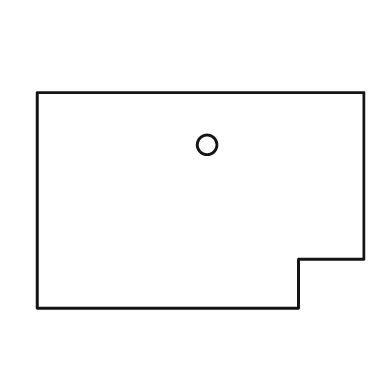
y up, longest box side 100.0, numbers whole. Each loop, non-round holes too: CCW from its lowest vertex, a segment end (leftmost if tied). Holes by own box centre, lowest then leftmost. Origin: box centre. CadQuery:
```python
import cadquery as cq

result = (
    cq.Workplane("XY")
    .moveTo(-50.0, -33.0)
    .lineTo(30.0, -33.0)
    .lineTo(30.0, -18.0)
    .lineTo(50.0, -18.0)
    .lineTo(50.0, 33.0)
    .lineTo(-50.0, 33.0)
    .close()
    .moveTo(2.0, 17.0)
    .circle(3.0)
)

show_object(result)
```